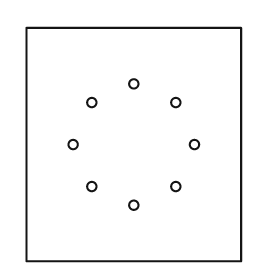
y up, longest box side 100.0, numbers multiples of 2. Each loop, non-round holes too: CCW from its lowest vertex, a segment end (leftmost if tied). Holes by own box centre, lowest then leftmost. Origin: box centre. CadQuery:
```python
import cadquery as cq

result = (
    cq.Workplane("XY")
    .moveTo(-46.0, -50.0)
    .lineTo(46.0, -50.0)
    .lineTo(46.0, 50.0)
    .lineTo(-46.0, 50.0)
    .close()
    .moveTo(0.0, -26.0)
    .circle(2.0)
    .moveTo(-18.0, -18.0)
    .circle(2.0)
    .moveTo(18.0, -18.0)
    .circle(2.0)
    .moveTo(-26.0, 0.0)
    .circle(2.0)
    .moveTo(26.0, 0.0)
    .circle(2.0)
    .moveTo(-18.0, 18.0)
    .circle(2.0)
    .moveTo(18.0, 18.0)
    .circle(2.0)
    .moveTo(0.0, 26.0)
    .circle(2.0)
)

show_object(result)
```